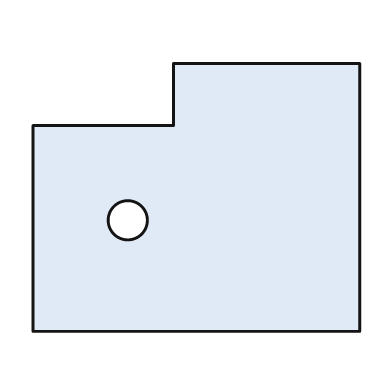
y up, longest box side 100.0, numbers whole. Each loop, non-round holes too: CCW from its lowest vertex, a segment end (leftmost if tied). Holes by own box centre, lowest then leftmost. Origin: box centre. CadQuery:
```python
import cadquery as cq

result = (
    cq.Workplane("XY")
    .moveTo(-50.0, -41.0)
    .lineTo(50.0, -41.0)
    .lineTo(50.0, 41.0)
    .lineTo(-7.0, 41.0)
    .lineTo(-7.0, 22.0)
    .lineTo(-50.0, 22.0)
    .close()
    .moveTo(-21.0, -7.0)
    .circle(6.0)
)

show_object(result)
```